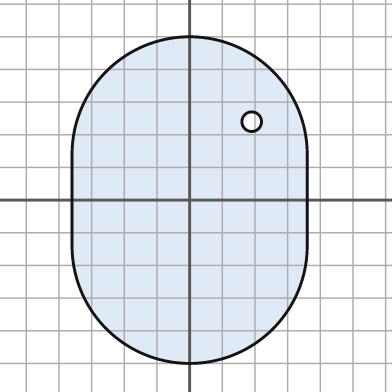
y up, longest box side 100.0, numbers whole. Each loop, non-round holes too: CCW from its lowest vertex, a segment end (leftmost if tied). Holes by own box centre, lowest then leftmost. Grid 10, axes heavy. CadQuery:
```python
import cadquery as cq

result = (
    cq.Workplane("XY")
    .moveTo(-36.0, -14.0)
    .threePointArc((0.0, -50.0), (36.0, -14.0))
    .lineTo(36.0, 14.0)
    .threePointArc((0.0, 50.0), (-36.0, 14.0))
    .close()
    .moveTo(19.0, 24.0)
    .circle(3.0)
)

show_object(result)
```